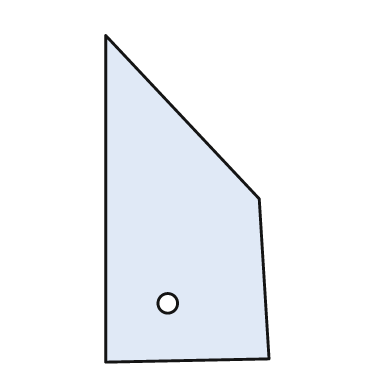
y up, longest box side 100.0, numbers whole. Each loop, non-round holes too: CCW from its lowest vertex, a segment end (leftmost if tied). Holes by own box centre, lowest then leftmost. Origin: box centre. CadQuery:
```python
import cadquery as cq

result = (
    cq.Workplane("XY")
    .moveTo(-25.0, -50.0)
    .lineTo(25.0, -49.0)
    .lineTo(22.0, 0.0)
    .lineTo(-25.0, 50.0)
    .close()
    .moveTo(-6.0, -32.0)
    .circle(3.0)
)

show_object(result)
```